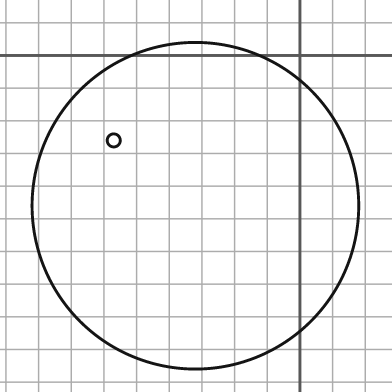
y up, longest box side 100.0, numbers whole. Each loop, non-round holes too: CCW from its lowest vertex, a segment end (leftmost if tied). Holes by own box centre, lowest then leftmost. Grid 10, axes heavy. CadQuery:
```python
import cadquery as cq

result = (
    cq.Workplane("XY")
    .moveTo(-32.0, -46.0)
    .circle(50.0)
    .moveTo(-57.0, -26.0)
    .circle(2.0)
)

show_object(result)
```